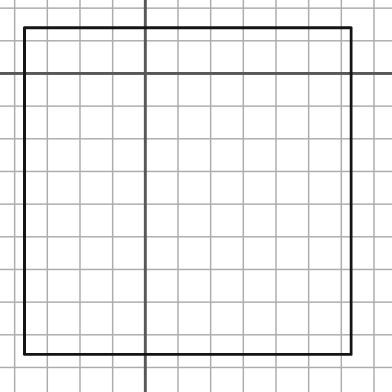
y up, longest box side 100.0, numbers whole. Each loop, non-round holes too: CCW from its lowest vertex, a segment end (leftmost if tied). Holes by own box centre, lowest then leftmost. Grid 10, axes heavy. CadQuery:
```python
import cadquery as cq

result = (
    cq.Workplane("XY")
    .moveTo(-37.0, -86.0)
    .lineTo(63.0, -86.0)
    .lineTo(63.0, 14.0)
    .lineTo(-37.0, 14.0)
    .close()
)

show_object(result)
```